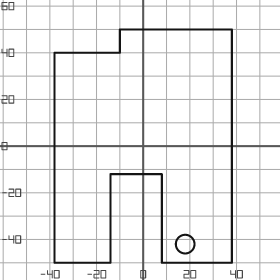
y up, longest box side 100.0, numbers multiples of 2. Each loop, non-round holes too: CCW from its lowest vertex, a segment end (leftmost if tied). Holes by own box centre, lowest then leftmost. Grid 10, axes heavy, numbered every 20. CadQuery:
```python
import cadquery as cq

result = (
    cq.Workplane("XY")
    .moveTo(-38.0, -50.0)
    .lineTo(-14.0, -50.0)
    .lineTo(-14.0, -12.0)
    .lineTo(8.0, -12.0)
    .lineTo(8.0, -50.0)
    .lineTo(38.0, -50.0)
    .lineTo(38.0, 50.0)
    .lineTo(-10.0, 50.0)
    .lineTo(-10.0, 40.0)
    .lineTo(-38.0, 40.0)
    .close()
    .moveTo(18.0, -42.0)
    .circle(4.0)
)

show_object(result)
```